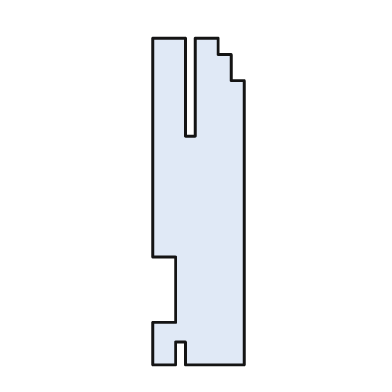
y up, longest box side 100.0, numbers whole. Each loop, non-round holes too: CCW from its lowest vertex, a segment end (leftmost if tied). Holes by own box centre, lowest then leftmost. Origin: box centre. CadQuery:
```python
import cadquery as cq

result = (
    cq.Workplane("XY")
    .moveTo(-14.0, -50.0)
    .lineTo(-7.0, -50.0)
    .lineTo(-7.0, -43.0)
    .lineTo(-4.0, -43.0)
    .lineTo(-4.0, -50.0)
    .lineTo(14.0, -50.0)
    .lineTo(14.0, 37.0)
    .lineTo(10.0, 37.0)
    .lineTo(10.0, 45.0)
    .lineTo(6.0, 45.0)
    .lineTo(6.0, 50.0)
    .lineTo(-1.0, 50.0)
    .lineTo(-1.0, 20.0)
    .lineTo(-4.0, 20.0)
    .lineTo(-4.0, 50.0)
    .lineTo(-14.0, 50.0)
    .lineTo(-14.0, -17.0)
    .lineTo(-7.0, -17.0)
    .lineTo(-7.0, -37.0)
    .lineTo(-14.0, -37.0)
    .close()
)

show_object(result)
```